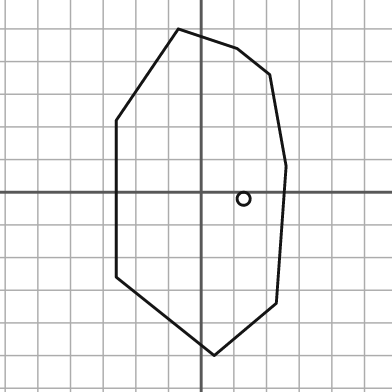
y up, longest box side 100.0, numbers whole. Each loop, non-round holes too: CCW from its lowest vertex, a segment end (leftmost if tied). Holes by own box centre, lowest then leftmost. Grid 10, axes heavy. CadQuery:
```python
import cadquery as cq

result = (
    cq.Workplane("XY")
    .moveTo(4.0, -50.0)
    .lineTo(23.0, -34.0)
    .lineTo(26.0, 8.0)
    .lineTo(21.0, 36.0)
    .lineTo(11.0, 44.0)
    .lineTo(-7.0, 50.0)
    .lineTo(-26.0, 22.0)
    .lineTo(-26.0, -26.0)
    .close()
    .moveTo(13.0, -2.0)
    .circle(2.0)
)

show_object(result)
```